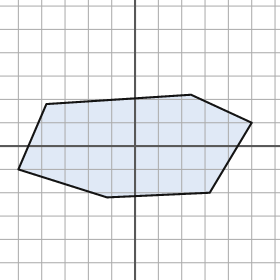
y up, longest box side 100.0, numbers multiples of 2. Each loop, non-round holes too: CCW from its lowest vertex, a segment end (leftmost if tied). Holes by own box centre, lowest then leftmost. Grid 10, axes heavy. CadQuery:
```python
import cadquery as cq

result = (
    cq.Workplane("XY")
    .moveTo(-12.0, -22.0)
    .lineTo(32.0, -20.0)
    .lineTo(50.0, 10.0)
    .lineTo(24.0, 22.0)
    .lineTo(-38.0, 18.0)
    .lineTo(-50.0, -10.0)
    .close()
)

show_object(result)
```